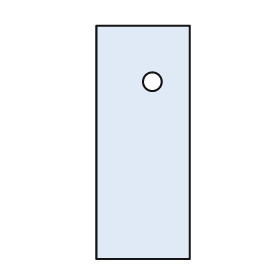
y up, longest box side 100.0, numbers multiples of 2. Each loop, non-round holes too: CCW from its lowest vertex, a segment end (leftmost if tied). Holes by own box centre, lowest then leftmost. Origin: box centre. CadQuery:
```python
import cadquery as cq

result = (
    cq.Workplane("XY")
    .moveTo(-20.0, -50.0)
    .lineTo(20.0, -50.0)
    .lineTo(20.0, 50.0)
    .lineTo(-20.0, 50.0)
    .close()
    .moveTo(4.0, 26.0)
    .circle(4.0)
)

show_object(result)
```